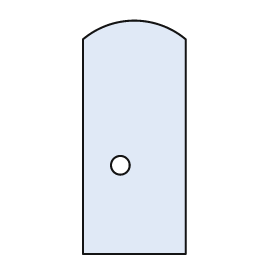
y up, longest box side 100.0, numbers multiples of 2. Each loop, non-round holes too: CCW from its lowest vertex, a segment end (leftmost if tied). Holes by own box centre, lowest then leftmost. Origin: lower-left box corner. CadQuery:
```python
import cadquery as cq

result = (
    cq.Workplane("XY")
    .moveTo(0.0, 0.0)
    .lineTo(44.0, 0.0)
    .lineTo(44.0, 92.0)
    .threePointArc((22.0, 100.0), (0.0, 92.0))
    .close()
    .moveTo(16.0, 38.0)
    .circle(4.0)
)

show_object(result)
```